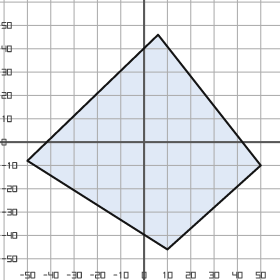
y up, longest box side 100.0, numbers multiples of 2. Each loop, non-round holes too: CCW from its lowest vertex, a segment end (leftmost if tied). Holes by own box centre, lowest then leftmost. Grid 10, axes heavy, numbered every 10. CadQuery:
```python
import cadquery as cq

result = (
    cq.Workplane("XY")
    .moveTo(10.0, -46.0)
    .lineTo(50.0, -10.0)
    .lineTo(6.0, 46.0)
    .lineTo(-50.0, -8.0)
    .close()
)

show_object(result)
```